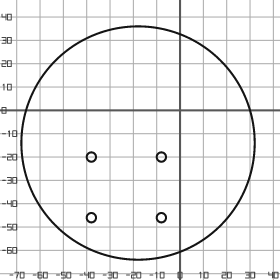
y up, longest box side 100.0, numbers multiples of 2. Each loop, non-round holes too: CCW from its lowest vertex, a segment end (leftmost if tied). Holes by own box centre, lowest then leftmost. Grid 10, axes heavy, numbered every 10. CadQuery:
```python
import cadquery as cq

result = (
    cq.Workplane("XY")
    .moveTo(-18.0, -14.0)
    .circle(50.0)
    .moveTo(-38.0, -46.0)
    .circle(2.0)
    .moveTo(-8.0, -46.0)
    .circle(2.0)
    .moveTo(-38.0, -20.0)
    .circle(2.0)
    .moveTo(-8.0, -20.0)
    .circle(2.0)
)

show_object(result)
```